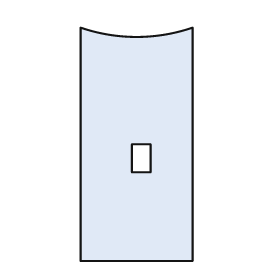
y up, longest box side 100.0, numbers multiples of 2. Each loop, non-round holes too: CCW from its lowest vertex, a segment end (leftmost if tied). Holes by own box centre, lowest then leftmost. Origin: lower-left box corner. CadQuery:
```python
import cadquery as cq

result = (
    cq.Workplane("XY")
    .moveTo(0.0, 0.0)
    .lineTo(48.0, 0.0)
    .lineTo(48.0, 100.0)
    .threePointArc((24.0, 96.0), (0.0, 100.0))
    .close()
    .moveTo(22.0, 38.0)
    .lineTo(30.0, 38.0)
    .lineTo(30.0, 50.0)
    .lineTo(22.0, 50.0)
    .close()
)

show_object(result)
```